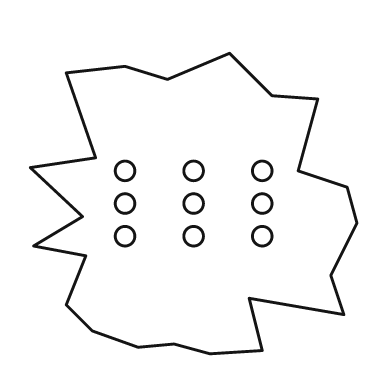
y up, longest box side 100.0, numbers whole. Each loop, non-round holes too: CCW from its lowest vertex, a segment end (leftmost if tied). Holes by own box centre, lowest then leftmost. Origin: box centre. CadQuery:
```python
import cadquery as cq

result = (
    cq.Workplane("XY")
    .moveTo(5.0, -46.0)
    .lineTo(21.0, -45.0)
    .lineTo(17.0, -29.0)
    .lineTo(46.0, -34.0)
    .lineTo(42.0, -22.0)
    .lineTo(50.0, -6.0)
    .lineTo(47.0, 5.0)
    .lineTo(32.0, 10.0)
    .lineTo(38.0, 32.0)
    .lineTo(24.0, 33.0)
    .lineTo(11.0, 46.0)
    .lineTo(-8.0, 38.0)
    .lineTo(-21.0, 42.0)
    .lineTo(-39.0, 40.0)
    .lineTo(-30.0, 14.0)
    .lineTo(-50.0, 11.0)
    .lineTo(-34.0, -4.0)
    .lineTo(-49.0, -13.0)
    .lineTo(-33.0, -16.0)
    .lineTo(-39.0, -31.0)
    .lineTo(-31.0, -39.0)
    .lineTo(-17.0, -44.0)
    .lineTo(-6.0, -43.0)
    .close()
    .moveTo(-21.0, -10.0)
    .circle(3.0)
    .moveTo(0.0, -10.0)
    .circle(3.0)
    .moveTo(21.0, -10.0)
    .circle(3.0)
    .moveTo(-21.0, 0.0)
    .circle(3.0)
    .moveTo(0.0, 0.0)
    .circle(3.0)
    .moveTo(21.0, 0.0)
    .circle(3.0)
    .moveTo(-21.0, 10.0)
    .circle(3.0)
    .moveTo(0.0, 10.0)
    .circle(3.0)
    .moveTo(21.0, 10.0)
    .circle(3.0)
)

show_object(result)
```